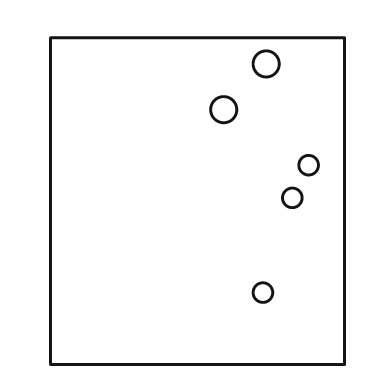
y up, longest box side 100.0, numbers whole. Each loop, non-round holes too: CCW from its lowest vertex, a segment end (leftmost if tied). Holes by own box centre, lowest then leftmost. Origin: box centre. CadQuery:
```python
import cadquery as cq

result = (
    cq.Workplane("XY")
    .moveTo(-45.0, -50.0)
    .lineTo(45.0, -50.0)
    .lineTo(45.0, 50.0)
    .lineTo(-45.0, 50.0)
    .close()
    .moveTo(20.0, -28.0)
    .circle(3.0)
    .moveTo(29.0, 1.0)
    .circle(3.0)
    .moveTo(34.0, 11.0)
    .circle(3.0)
    .moveTo(8.0, 28.0)
    .circle(4.0)
    .moveTo(21.0, 42.0)
    .circle(4.0)
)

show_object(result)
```